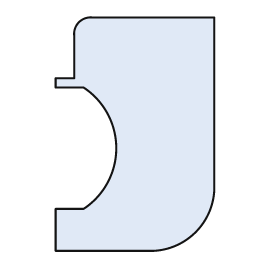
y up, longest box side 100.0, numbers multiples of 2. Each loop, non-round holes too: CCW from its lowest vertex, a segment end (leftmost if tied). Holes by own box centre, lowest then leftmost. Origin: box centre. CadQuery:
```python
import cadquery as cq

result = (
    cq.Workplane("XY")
    .moveTo(-34.0, -50.0)
    .lineTo(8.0, -50.0)
    .threePointArc((26.0, -42.0), (34.0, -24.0))
    .lineTo(34.0, 50.0)
    .lineTo(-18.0, 50.0)
    .threePointArc((-24.0, 48.0), (-26.0, 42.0))
    .lineTo(-26.0, 24.0)
    .lineTo(-34.0, 24.0)
    .lineTo(-34.0, 20.0)
    .lineTo(-22.0, 20.0)
    .threePointArc((-8.0, -6.0), (-22.0, -32.0))
    .lineTo(-34.0, -32.0)
    .close()
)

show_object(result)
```